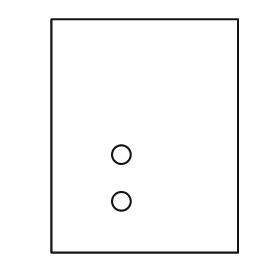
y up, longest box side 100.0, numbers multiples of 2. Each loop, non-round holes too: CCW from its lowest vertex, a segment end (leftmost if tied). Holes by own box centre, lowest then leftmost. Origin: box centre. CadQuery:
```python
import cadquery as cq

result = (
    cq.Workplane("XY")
    .moveTo(-40.0, -50.0)
    .lineTo(40.0, -50.0)
    .lineTo(40.0, 50.0)
    .lineTo(-40.0, 50.0)
    .close()
    .moveTo(-10.0, -28.0)
    .circle(4.0)
    .moveTo(-10.0, -8.0)
    .circle(4.0)
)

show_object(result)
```